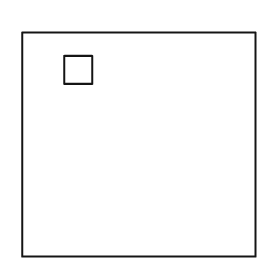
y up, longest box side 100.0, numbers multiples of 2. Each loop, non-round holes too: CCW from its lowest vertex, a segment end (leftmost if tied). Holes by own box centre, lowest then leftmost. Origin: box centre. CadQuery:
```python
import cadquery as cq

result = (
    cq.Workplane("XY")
    .moveTo(-50.0, -48.0)
    .lineTo(50.0, -48.0)
    .lineTo(50.0, 48.0)
    .lineTo(-50.0, 48.0)
    .close()
    .moveTo(-32.0, 26.0)
    .lineTo(-20.0, 26.0)
    .lineTo(-20.0, 38.0)
    .lineTo(-32.0, 38.0)
    .close()
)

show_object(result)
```